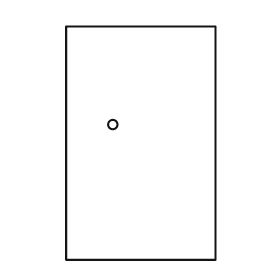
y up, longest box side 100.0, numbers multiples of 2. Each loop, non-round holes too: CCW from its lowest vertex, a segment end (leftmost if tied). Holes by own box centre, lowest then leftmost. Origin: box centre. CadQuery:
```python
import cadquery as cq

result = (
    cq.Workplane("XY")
    .moveTo(-32.0, -50.0)
    .lineTo(32.0, -50.0)
    .lineTo(32.0, 50.0)
    .lineTo(-32.0, 50.0)
    .close()
    .moveTo(-12.0, 8.0)
    .circle(2.0)
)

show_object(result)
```